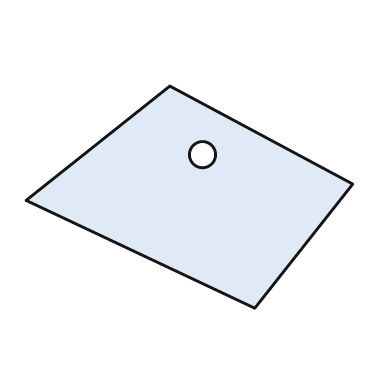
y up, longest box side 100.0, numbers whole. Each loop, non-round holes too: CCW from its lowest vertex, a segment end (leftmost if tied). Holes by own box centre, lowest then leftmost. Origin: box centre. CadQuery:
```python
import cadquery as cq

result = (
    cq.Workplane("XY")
    .moveTo(20.0, -34.0)
    .lineTo(50.0, 4.0)
    .lineTo(-6.0, 34.0)
    .lineTo(-50.0, -1.0)
    .close()
    .moveTo(4.0, 13.0)
    .circle(4.0)
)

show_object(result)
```